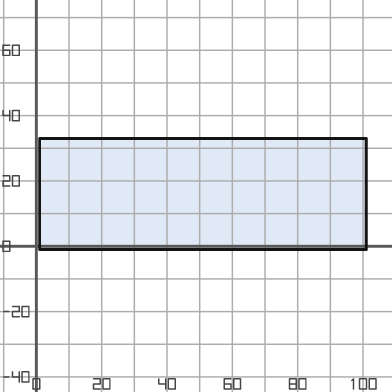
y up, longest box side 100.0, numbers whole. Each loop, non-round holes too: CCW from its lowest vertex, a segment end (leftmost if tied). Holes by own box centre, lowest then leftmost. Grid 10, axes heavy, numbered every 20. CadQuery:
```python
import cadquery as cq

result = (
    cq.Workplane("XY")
    .moveTo(1.0, -1.0)
    .lineTo(101.0, -1.0)
    .lineTo(101.0, 33.0)
    .lineTo(1.0, 33.0)
    .close()
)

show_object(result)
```